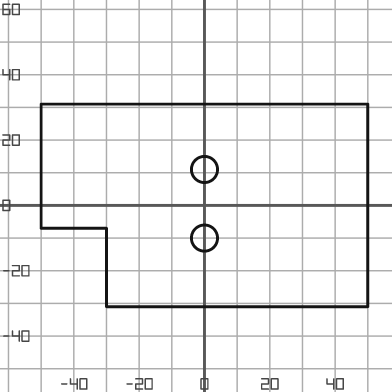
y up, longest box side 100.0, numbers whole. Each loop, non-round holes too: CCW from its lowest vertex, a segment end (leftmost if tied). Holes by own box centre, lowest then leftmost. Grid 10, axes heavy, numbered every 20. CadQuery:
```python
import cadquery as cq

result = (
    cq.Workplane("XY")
    .moveTo(-30.0, -31.0)
    .lineTo(50.0, -31.0)
    .lineTo(50.0, 31.0)
    .lineTo(-50.0, 31.0)
    .lineTo(-50.0, -7.0)
    .lineTo(-30.0, -7.0)
    .close()
    .moveTo(0.0, -10.0)
    .circle(4.0)
    .moveTo(0.0, 11.0)
    .circle(4.0)
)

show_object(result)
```